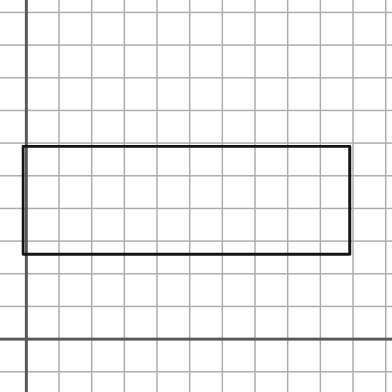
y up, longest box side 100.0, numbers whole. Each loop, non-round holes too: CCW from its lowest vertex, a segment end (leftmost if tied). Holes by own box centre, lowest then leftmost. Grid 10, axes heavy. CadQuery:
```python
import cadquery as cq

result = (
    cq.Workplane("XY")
    .moveTo(-1.0, 26.0)
    .lineTo(99.0, 26.0)
    .lineTo(99.0, 59.0)
    .lineTo(-1.0, 59.0)
    .close()
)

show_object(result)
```